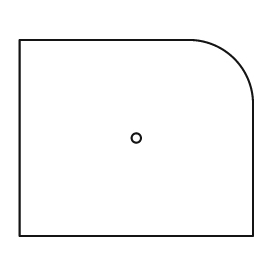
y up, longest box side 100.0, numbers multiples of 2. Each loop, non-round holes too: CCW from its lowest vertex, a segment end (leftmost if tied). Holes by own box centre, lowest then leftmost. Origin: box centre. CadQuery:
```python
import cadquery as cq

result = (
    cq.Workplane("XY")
    .moveTo(-50.0, -42.0)
    .lineTo(50.0, -42.0)
    .lineTo(50.0, 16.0)
    .threePointArc((42.0, 34.0), (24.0, 42.0))
    .lineTo(-50.0, 42.0)
    .close()
    .moveTo(0.0, 0.0)
    .circle(2.0)
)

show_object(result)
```